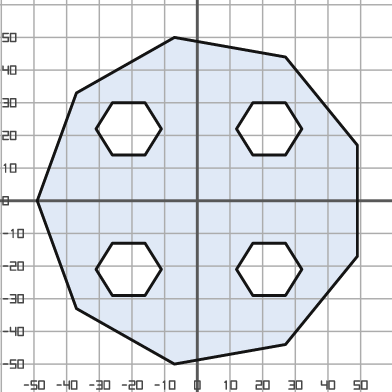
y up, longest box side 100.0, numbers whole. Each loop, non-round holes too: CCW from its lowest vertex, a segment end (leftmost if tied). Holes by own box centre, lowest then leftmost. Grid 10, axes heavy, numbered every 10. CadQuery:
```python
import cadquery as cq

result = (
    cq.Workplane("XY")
    .moveTo(-7.0, -50.0)
    .lineTo(27.0, -44.0)
    .lineTo(49.0, -17.0)
    .lineTo(49.0, 17.0)
    .lineTo(27.0, 44.0)
    .lineTo(-7.0, 50.0)
    .lineTo(-37.0, 33.0)
    .lineTo(-49.0, 0.0)
    .lineTo(-37.0, -33.0)
    .close()
    .moveTo(-26.0, -29.0)
    .lineTo(-16.0, -29.0)
    .lineTo(-11.0, -21.0)
    .lineTo(-16.0, -13.0)
    .lineTo(-26.0, -13.0)
    .lineTo(-31.0, -21.0)
    .close()
    .moveTo(17.0, -29.0)
    .lineTo(27.0, -29.0)
    .lineTo(32.0, -21.0)
    .lineTo(27.0, -13.0)
    .lineTo(17.0, -13.0)
    .lineTo(12.0, -21.0)
    .close()
    .moveTo(-26.0, 14.0)
    .lineTo(-16.0, 14.0)
    .lineTo(-11.0, 22.0)
    .lineTo(-16.0, 30.0)
    .lineTo(-26.0, 30.0)
    .lineTo(-31.0, 22.0)
    .close()
    .moveTo(17.0, 14.0)
    .lineTo(27.0, 14.0)
    .lineTo(32.0, 22.0)
    .lineTo(27.0, 30.0)
    .lineTo(17.0, 30.0)
    .lineTo(12.0, 22.0)
    .close()
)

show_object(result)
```